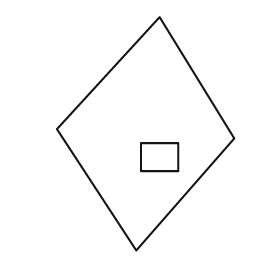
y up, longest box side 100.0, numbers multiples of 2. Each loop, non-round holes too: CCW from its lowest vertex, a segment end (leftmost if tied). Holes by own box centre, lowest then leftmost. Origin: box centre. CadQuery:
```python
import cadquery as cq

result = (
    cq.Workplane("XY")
    .moveTo(-4.0, -50.0)
    .lineTo(38.0, -2.0)
    .lineTo(6.0, 50.0)
    .lineTo(-38.0, 2.0)
    .close()
    .moveTo(-2.0, -16.0)
    .lineTo(14.0, -16.0)
    .lineTo(14.0, -4.0)
    .lineTo(-2.0, -4.0)
    .close()
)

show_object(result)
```